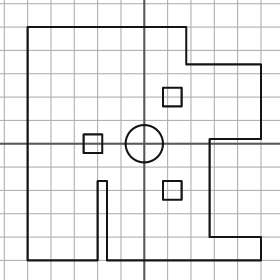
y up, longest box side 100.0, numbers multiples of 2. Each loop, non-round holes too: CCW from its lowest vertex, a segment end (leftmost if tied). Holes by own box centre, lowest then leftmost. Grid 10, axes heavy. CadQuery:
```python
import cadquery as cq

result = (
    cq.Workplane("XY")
    .moveTo(-50.0, -50.0)
    .lineTo(-20.0, -50.0)
    .lineTo(-20.0, -16.0)
    .lineTo(-16.0, -16.0)
    .lineTo(-16.0, -50.0)
    .lineTo(50.0, -50.0)
    .lineTo(50.0, -40.0)
    .lineTo(28.0, -40.0)
    .lineTo(28.0, 2.0)
    .lineTo(50.0, 2.0)
    .lineTo(50.0, 34.0)
    .lineTo(18.0, 34.0)
    .lineTo(18.0, 50.0)
    .lineTo(-50.0, 50.0)
    .close()
    .moveTo(8.0, -24.0)
    .lineTo(16.0, -24.0)
    .lineTo(16.0, -16.0)
    .lineTo(8.0, -16.0)
    .close()
    .moveTo(-26.0, -4.0)
    .lineTo(-18.0, -4.0)
    .lineTo(-18.0, 4.0)
    .lineTo(-26.0, 4.0)
    .close()
    .moveTo(0.0, 0.0)
    .circle(8.0)
    .moveTo(8.0, 16.0)
    .lineTo(16.0, 16.0)
    .lineTo(16.0, 24.0)
    .lineTo(8.0, 24.0)
    .close()
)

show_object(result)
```